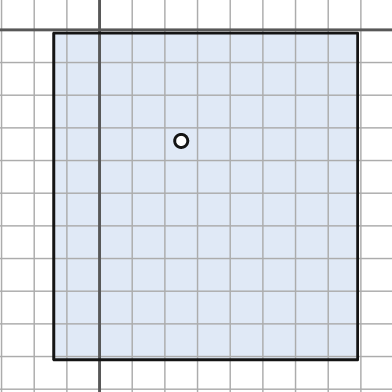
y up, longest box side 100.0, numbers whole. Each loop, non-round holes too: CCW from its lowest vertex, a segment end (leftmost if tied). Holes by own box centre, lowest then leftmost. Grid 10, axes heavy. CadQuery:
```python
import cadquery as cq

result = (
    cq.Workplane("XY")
    .moveTo(-14.0, -101.0)
    .lineTo(79.0, -101.0)
    .lineTo(79.0, -1.0)
    .lineTo(-14.0, -1.0)
    .close()
    .moveTo(25.0, -34.0)
    .circle(2.0)
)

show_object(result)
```